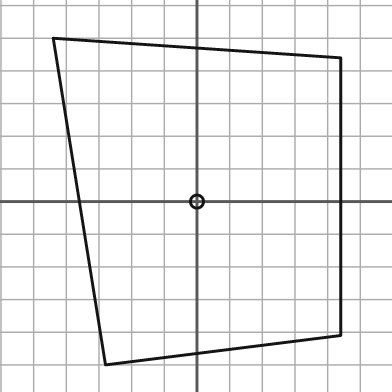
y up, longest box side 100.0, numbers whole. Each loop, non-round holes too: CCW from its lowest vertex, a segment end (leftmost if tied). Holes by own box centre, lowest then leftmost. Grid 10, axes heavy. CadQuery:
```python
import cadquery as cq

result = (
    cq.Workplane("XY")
    .moveTo(-28.0, -50.0)
    .lineTo(44.0, -41.0)
    .lineTo(44.0, 44.0)
    .lineTo(-44.0, 50.0)
    .close()
    .moveTo(0.0, 0.0)
    .circle(2.0)
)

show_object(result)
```